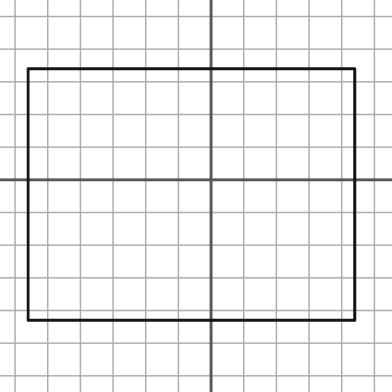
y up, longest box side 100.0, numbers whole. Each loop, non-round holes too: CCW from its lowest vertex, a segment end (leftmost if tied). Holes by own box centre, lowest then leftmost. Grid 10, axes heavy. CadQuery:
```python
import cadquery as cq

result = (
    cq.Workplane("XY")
    .moveTo(-56.0, -43.0)
    .lineTo(44.0, -43.0)
    .lineTo(44.0, 34.0)
    .lineTo(-56.0, 34.0)
    .close()
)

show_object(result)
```